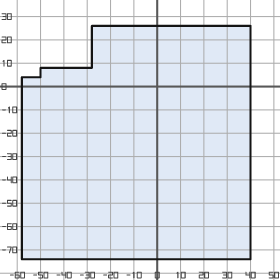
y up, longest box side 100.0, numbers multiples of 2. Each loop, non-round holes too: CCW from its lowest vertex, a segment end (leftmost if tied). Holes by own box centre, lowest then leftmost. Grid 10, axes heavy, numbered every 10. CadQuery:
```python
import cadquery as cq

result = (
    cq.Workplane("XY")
    .moveTo(-58.0, -74.0)
    .lineTo(40.0, -74.0)
    .lineTo(40.0, 26.0)
    .lineTo(-28.0, 26.0)
    .lineTo(-28.0, 8.0)
    .lineTo(-50.0, 8.0)
    .lineTo(-50.0, 4.0)
    .lineTo(-58.0, 4.0)
    .close()
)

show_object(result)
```